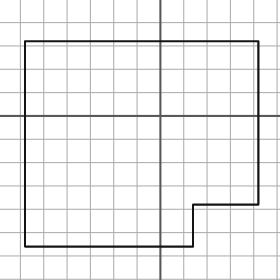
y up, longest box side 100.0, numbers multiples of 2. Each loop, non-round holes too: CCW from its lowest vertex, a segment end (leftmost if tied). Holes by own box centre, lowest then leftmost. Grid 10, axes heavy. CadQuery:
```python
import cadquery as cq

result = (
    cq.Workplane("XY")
    .moveTo(-58.0, -56.0)
    .lineTo(14.0, -56.0)
    .lineTo(14.0, -38.0)
    .lineTo(42.0, -38.0)
    .lineTo(42.0, 32.0)
    .lineTo(-58.0, 32.0)
    .close()
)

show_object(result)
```